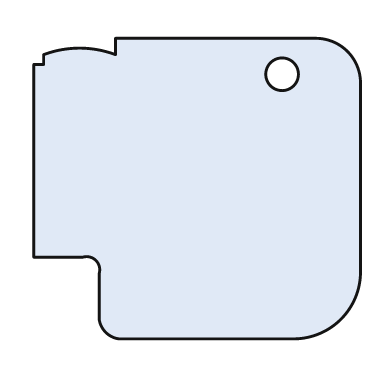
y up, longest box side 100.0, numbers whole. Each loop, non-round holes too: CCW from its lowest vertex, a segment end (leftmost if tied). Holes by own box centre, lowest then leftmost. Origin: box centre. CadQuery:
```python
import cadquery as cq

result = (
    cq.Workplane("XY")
    .moveTo(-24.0, -46.0)
    .lineTo(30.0, -46.0)
    .threePointArc((44.0, -40.0), (50.0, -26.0))
    .lineTo(50.0, 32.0)
    .threePointArc((46.0, 42.0), (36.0, 46.0))
    .lineTo(-25.0, 46.0)
    .lineTo(-25.0, 41.0)
    .threePointArc((-36.0, 43.0), (-47.0, 41.0))
    .lineTo(-47.0, 38.0)
    .lineTo(-50.0, 38.0)
    .lineTo(-50.0, -21.0)
    .lineTo(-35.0, -21.0)
    .threePointArc((-31.0, -22.0), (-30.0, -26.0))
    .lineTo(-30.0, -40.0)
    .threePointArc((-28.0, -44.0), (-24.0, -46.0))
    .close()
    .moveTo(26.0, 35.0)
    .circle(5.0)
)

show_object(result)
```